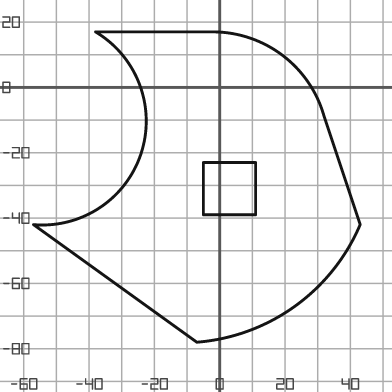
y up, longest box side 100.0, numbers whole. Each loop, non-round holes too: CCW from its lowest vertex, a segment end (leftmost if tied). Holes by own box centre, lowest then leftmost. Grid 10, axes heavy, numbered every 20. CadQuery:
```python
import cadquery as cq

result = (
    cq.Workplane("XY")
    .moveTo(-7.0, -78.0)
    .threePointArc((23.0, -67.0), (43.0, -42.0))
    .lineTo(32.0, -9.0)
    .threePointArc((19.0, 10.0), (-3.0, 17.0))
    .lineTo(-38.0, 17.0)
    .threePointArc((-24.0, -20.0), (-57.0, -42.0))
    .close()
    .moveTo(-5.0, -39.0)
    .lineTo(11.0, -39.0)
    .lineTo(11.0, -23.0)
    .lineTo(-5.0, -23.0)
    .close()
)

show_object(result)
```